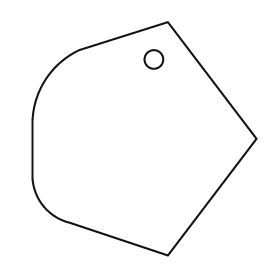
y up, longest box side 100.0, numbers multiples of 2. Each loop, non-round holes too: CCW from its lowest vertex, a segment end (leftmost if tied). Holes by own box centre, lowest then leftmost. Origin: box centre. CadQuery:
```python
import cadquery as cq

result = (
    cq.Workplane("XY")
    .moveTo(10.0, -50.0)
    .lineTo(48.0, 0.0)
    .lineTo(10.0, 50.0)
    .lineTo(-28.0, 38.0)
    .threePointArc((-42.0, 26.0), (-48.0, 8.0))
    .lineTo(-48.0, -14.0)
    .threePointArc((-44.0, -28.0), (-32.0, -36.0))
    .close()
    .moveTo(4.0, 34.0)
    .circle(4.0)
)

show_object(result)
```